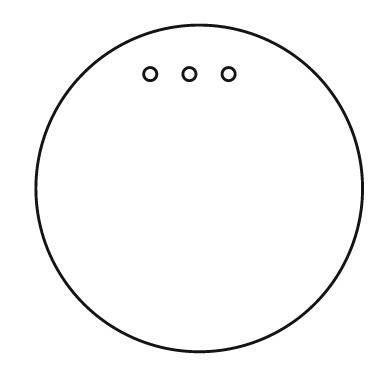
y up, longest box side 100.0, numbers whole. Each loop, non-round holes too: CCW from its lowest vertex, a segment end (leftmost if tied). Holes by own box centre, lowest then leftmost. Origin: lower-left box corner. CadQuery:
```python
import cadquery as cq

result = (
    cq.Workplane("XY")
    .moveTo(50.0, 50.0)
    .circle(50.0)
    .moveTo(35.0, 85.0)
    .circle(2.0)
    .moveTo(47.0, 85.0)
    .circle(2.0)
    .moveTo(59.0, 85.0)
    .circle(2.0)
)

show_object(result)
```